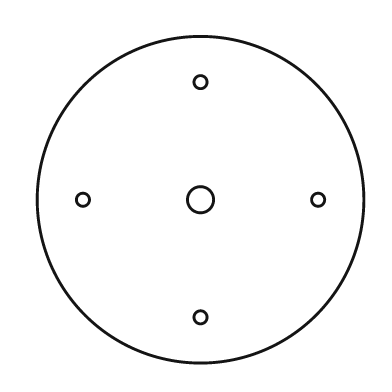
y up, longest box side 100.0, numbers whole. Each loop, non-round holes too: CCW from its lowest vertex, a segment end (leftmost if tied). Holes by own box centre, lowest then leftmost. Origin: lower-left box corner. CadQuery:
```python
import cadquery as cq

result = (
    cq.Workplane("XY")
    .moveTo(50.0, 50.0)
    .circle(50.0)
    .moveTo(50.0, 14.0)
    .circle(2.0)
    .moveTo(14.0, 50.0)
    .circle(2.0)
    .moveTo(50.0, 50.0)
    .circle(4.0)
    .moveTo(86.0, 50.0)
    .circle(2.0)
    .moveTo(50.0, 86.0)
    .circle(2.0)
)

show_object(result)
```